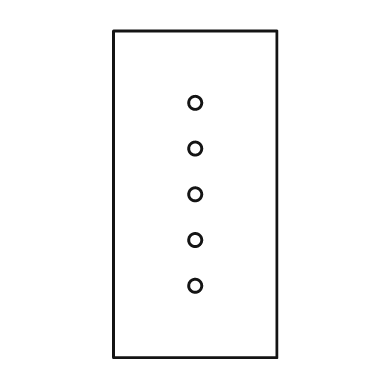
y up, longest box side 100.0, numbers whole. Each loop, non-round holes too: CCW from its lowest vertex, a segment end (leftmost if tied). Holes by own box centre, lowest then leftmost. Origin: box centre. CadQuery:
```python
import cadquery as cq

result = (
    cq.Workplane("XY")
    .moveTo(-25.0, -50.0)
    .lineTo(25.0, -50.0)
    .lineTo(25.0, 50.0)
    .lineTo(-25.0, 50.0)
    .close()
    .moveTo(0.0, -28.0)
    .circle(2.0)
    .moveTo(0.0, -14.0)
    .circle(2.0)
    .moveTo(0.0, 0.0)
    .circle(2.0)
    .moveTo(0.0, 14.0)
    .circle(2.0)
    .moveTo(0.0, 28.0)
    .circle(2.0)
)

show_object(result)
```